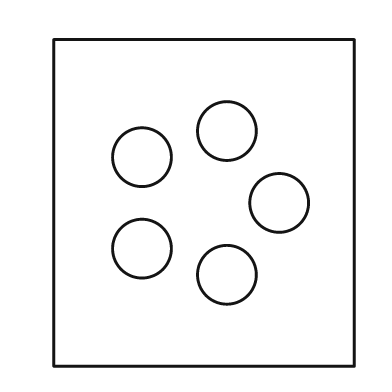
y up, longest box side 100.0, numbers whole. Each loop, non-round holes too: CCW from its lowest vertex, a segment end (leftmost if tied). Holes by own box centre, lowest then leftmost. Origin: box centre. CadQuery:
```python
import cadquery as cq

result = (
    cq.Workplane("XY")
    .moveTo(-46.0, -50.0)
    .lineTo(46.0, -50.0)
    .lineTo(46.0, 50.0)
    .lineTo(-46.0, 50.0)
    .close()
    .moveTo(7.0, -22.0)
    .circle(9.0)
    .moveTo(-19.0, -14.0)
    .circle(9.0)
    .moveTo(23.0, 0.0)
    .circle(9.0)
    .moveTo(-19.0, 14.0)
    .circle(9.0)
    .moveTo(7.0, 22.0)
    .circle(9.0)
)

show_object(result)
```